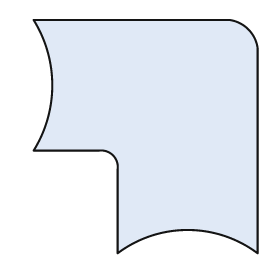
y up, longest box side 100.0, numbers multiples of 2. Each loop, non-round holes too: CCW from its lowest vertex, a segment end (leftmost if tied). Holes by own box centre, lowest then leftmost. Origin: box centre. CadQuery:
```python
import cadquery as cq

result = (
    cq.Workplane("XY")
    .moveTo(-12.0, -50.0)
    .threePointArc((18.0, -40.0), (48.0, -50.0))
    .lineTo(48.0, 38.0)
    .threePointArc((44.0, 46.0), (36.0, 50.0))
    .lineTo(-48.0, 50.0)
    .threePointArc((-40.0, 22.0), (-48.0, -6.0))
    .lineTo(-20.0, -6.0)
    .threePointArc((-14.0, -8.0), (-12.0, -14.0))
    .close()
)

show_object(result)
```